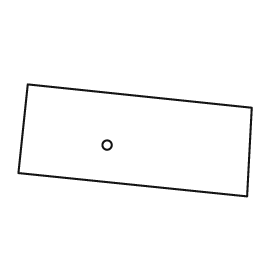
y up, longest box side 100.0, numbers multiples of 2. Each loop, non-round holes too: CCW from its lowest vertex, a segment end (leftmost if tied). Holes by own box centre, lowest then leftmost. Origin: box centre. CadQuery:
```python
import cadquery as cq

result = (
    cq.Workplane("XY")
    .moveTo(48.0, -24.0)
    .lineTo(50.0, 14.0)
    .lineTo(-46.0, 24.0)
    .lineTo(-50.0, -14.0)
    .close()
    .moveTo(-12.0, -2.0)
    .circle(2.0)
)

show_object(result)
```